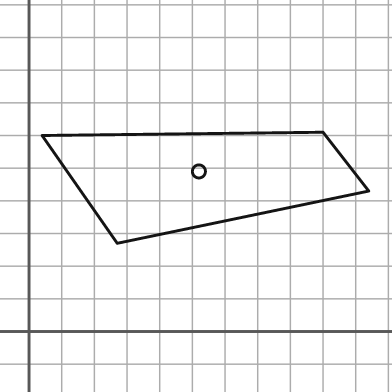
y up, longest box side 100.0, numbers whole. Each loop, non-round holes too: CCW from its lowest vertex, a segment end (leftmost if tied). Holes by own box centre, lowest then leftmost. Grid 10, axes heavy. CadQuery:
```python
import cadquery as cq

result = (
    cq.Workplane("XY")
    .moveTo(27.0, 27.0)
    .lineTo(104.0, 43.0)
    .lineTo(90.0, 61.0)
    .lineTo(4.0, 60.0)
    .close()
    .moveTo(52.0, 49.0)
    .circle(2.0)
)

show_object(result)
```